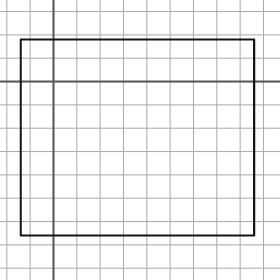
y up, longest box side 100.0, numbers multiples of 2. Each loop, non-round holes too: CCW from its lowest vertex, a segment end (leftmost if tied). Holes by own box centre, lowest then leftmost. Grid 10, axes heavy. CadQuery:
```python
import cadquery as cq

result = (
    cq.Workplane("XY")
    .moveTo(-14.0, -66.0)
    .lineTo(86.0, -66.0)
    .lineTo(86.0, 18.0)
    .lineTo(-14.0, 18.0)
    .close()
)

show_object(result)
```